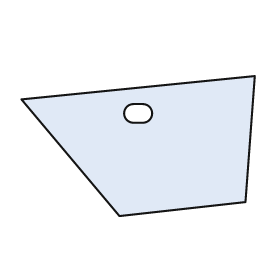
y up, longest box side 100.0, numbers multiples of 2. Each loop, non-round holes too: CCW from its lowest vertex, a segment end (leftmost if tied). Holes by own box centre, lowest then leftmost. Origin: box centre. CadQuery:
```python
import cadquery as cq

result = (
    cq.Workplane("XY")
    .moveTo(-8.0, -30.0)
    .lineTo(46.0, -24.0)
    .lineTo(50.0, 30.0)
    .lineTo(-50.0, 20.0)
    .close()
    .moveTo(-2.0, 10.0)
    .lineTo(2.0, 10.0)
    .threePointArc((6.0, 14.0), (2.0, 18.0))
    .lineTo(-2.0, 18.0)
    .threePointArc((-6.0, 14.0), (-2.0, 10.0))
    .close()
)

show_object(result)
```